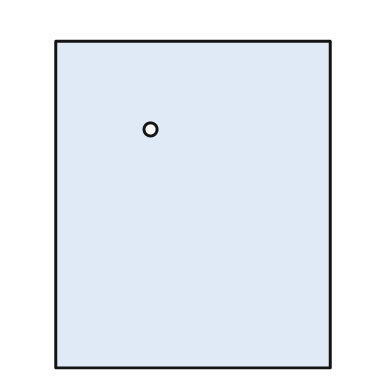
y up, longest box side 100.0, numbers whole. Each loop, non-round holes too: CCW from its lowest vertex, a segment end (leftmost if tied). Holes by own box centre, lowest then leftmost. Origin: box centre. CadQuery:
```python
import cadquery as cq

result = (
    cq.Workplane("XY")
    .moveTo(-42.0, -50.0)
    .lineTo(42.0, -50.0)
    .lineTo(42.0, 50.0)
    .lineTo(-42.0, 50.0)
    .close()
    .moveTo(-13.0, 23.0)
    .circle(2.0)
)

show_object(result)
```